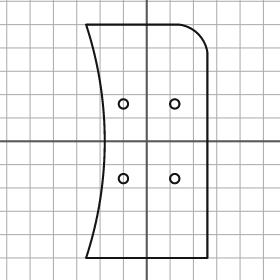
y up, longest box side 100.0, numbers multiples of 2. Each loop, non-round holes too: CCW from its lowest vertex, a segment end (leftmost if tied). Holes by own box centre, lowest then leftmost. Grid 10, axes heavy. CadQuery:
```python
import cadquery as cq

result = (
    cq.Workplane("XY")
    .moveTo(-26.0, -50.0)
    .lineTo(26.0, -50.0)
    .lineTo(26.0, 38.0)
    .threePointArc((22.0, 46.0), (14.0, 50.0))
    .lineTo(-26.0, 50.0)
    .threePointArc((-18.0, 0.0), (-26.0, -50.0))
    .close()
    .moveTo(-10.0, -16.0)
    .circle(2.0)
    .moveTo(12.0, -16.0)
    .circle(2.0)
    .moveTo(-10.0, 16.0)
    .circle(2.0)
    .moveTo(12.0, 16.0)
    .circle(2.0)
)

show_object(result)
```